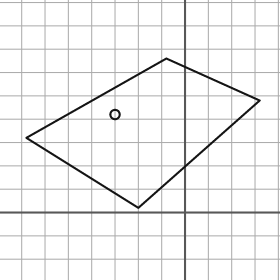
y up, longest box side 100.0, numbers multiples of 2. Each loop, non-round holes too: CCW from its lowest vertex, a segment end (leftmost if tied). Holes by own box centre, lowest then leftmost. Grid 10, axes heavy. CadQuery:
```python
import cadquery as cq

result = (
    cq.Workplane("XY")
    .moveTo(-20.0, 2.0)
    .lineTo(32.0, 48.0)
    .lineTo(-8.0, 66.0)
    .lineTo(-68.0, 32.0)
    .close()
    .moveTo(-30.0, 42.0)
    .circle(2.0)
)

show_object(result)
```